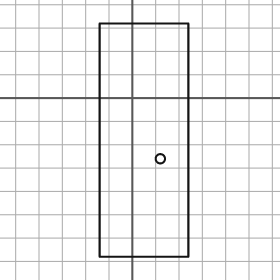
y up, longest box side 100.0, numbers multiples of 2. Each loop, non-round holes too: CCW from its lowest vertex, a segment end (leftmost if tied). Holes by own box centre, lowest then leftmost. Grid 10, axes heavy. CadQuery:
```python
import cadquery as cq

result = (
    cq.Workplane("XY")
    .moveTo(-14.0, -68.0)
    .lineTo(24.0, -68.0)
    .lineTo(24.0, 32.0)
    .lineTo(-14.0, 32.0)
    .close()
    .moveTo(12.0, -26.0)
    .circle(2.0)
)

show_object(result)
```